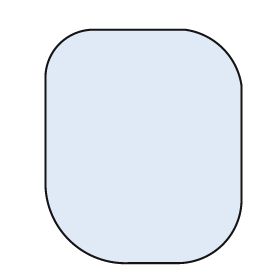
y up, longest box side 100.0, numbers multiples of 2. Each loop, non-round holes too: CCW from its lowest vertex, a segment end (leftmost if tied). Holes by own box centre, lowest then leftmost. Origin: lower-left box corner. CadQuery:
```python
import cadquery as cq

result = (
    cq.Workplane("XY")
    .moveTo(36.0, 0.0)
    .lineTo(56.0, 0.0)
    .threePointArc((76.0, 8.0), (84.0, 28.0))
    .lineTo(84.0, 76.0)
    .threePointArc((76.0, 92.0), (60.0, 100.0))
    .lineTo(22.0, 100.0)
    .threePointArc((6.0, 94.0), (0.0, 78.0))
    .lineTo(0.0, 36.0)
    .threePointArc((10.0, 10.0), (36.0, 0.0))
    .close()
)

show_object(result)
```